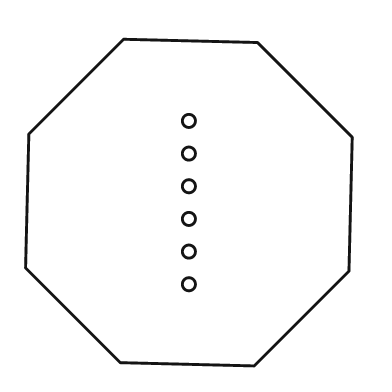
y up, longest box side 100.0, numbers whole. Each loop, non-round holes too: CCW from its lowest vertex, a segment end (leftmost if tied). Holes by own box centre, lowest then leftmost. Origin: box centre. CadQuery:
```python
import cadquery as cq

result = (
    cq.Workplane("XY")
    .moveTo(20.0, -50.0)
    .lineTo(49.0, -21.0)
    .lineTo(50.0, 20.0)
    .lineTo(21.0, 49.0)
    .lineTo(-20.0, 50.0)
    .lineTo(-49.0, 21.0)
    .lineTo(-50.0, -20.0)
    .lineTo(-21.0, -49.0)
    .close()
    .moveTo(0.0, -25.0)
    .circle(2.0)
    .moveTo(0.0, -15.0)
    .circle(2.0)
    .moveTo(0.0, -5.0)
    .circle(2.0)
    .moveTo(0.0, 5.0)
    .circle(2.0)
    .moveTo(0.0, 15.0)
    .circle(2.0)
    .moveTo(0.0, 25.0)
    .circle(2.0)
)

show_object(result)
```